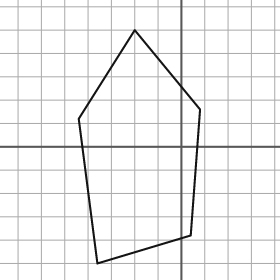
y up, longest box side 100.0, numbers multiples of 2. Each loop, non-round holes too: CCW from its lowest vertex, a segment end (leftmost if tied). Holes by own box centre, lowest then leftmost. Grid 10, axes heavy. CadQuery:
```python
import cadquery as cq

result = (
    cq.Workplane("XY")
    .moveTo(-36.0, -50.0)
    .lineTo(4.0, -38.0)
    .lineTo(8.0, 16.0)
    .lineTo(-20.0, 50.0)
    .lineTo(-44.0, 12.0)
    .close()
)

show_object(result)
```